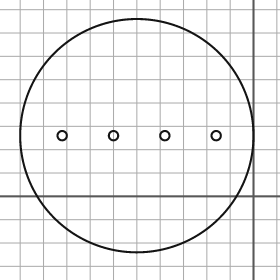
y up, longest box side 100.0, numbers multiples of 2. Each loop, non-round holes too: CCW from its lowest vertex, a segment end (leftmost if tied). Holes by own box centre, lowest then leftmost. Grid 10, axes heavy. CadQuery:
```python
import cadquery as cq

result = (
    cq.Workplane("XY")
    .moveTo(-50.0, 26.0)
    .circle(50.0)
    .moveTo(-82.0, 26.0)
    .circle(2.0)
    .moveTo(-60.0, 26.0)
    .circle(2.0)
    .moveTo(-38.0, 26.0)
    .circle(2.0)
    .moveTo(-16.0, 26.0)
    .circle(2.0)
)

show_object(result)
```